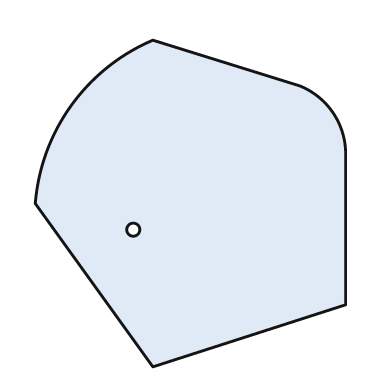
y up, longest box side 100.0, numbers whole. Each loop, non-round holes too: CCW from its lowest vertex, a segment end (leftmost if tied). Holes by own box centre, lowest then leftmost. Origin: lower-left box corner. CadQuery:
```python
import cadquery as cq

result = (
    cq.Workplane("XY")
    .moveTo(36.0, 0.0)
    .lineTo(95.0, 19.0)
    .lineTo(95.0, 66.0)
    .threePointArc((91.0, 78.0), (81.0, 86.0))
    .lineTo(36.0, 100.0)
    .threePointArc((11.0, 80.0), (0.0, 50.0))
    .close()
    .moveTo(30.0, 42.0)
    .circle(2.0)
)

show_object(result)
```